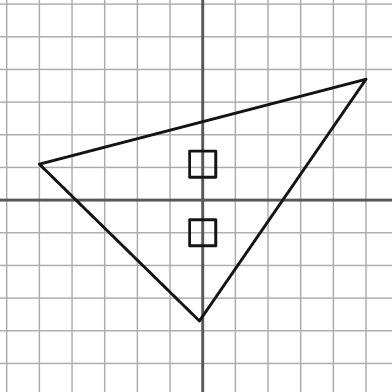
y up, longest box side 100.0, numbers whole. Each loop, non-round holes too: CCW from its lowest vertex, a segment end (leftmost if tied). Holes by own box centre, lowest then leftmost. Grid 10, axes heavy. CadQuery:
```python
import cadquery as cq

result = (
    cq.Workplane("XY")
    .moveTo(-1.0, -37.0)
    .lineTo(50.0, 37.0)
    .lineTo(-50.0, 11.0)
    .close()
    .moveTo(-4.0, -14.0)
    .lineTo(4.0, -14.0)
    .lineTo(4.0, -6.0)
    .lineTo(-4.0, -6.0)
    .close()
    .moveTo(-4.0, 7.0)
    .lineTo(4.0, 7.0)
    .lineTo(4.0, 15.0)
    .lineTo(-4.0, 15.0)
    .close()
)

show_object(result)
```